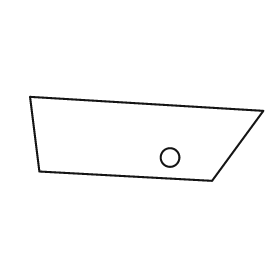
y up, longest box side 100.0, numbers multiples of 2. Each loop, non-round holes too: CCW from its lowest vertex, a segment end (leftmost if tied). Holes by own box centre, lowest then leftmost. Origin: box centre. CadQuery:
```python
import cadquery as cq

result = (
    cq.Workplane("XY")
    .moveTo(28.0, -18.0)
    .lineTo(50.0, 12.0)
    .lineTo(-50.0, 18.0)
    .lineTo(-46.0, -14.0)
    .close()
    .moveTo(10.0, -8.0)
    .circle(4.0)
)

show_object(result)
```